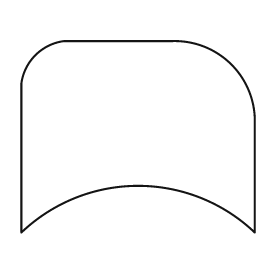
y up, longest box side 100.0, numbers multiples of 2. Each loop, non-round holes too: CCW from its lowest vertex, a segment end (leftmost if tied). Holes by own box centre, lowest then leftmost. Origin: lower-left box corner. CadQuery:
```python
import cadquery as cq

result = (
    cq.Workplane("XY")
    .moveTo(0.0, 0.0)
    .threePointArc((50.0, 20.0), (100.0, 0.0))
    .lineTo(100.0, 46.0)
    .threePointArc((90.0, 72.0), (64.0, 82.0))
    .lineTo(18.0, 82.0)
    .threePointArc((6.0, 76.0), (0.0, 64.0))
    .close()
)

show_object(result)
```